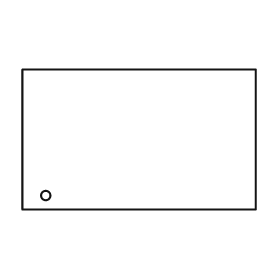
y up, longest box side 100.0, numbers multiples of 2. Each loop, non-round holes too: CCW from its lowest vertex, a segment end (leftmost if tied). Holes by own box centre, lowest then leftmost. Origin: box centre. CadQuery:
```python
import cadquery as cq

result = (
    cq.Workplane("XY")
    .moveTo(-50.0, -30.0)
    .lineTo(50.0, -30.0)
    .lineTo(50.0, 30.0)
    .lineTo(-50.0, 30.0)
    .close()
    .moveTo(-40.0, -24.0)
    .circle(2.0)
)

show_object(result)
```